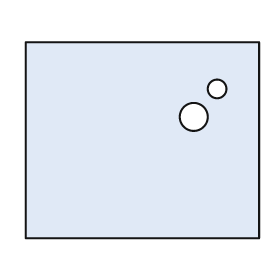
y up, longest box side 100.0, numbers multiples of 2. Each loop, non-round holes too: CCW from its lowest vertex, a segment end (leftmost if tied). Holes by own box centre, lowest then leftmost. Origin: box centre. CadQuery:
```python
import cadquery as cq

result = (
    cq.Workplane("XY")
    .moveTo(-50.0, -42.0)
    .lineTo(50.0, -42.0)
    .lineTo(50.0, 42.0)
    .lineTo(-50.0, 42.0)
    .close()
    .moveTo(22.0, 10.0)
    .circle(6.0)
    .moveTo(32.0, 22.0)
    .circle(4.0)
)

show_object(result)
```